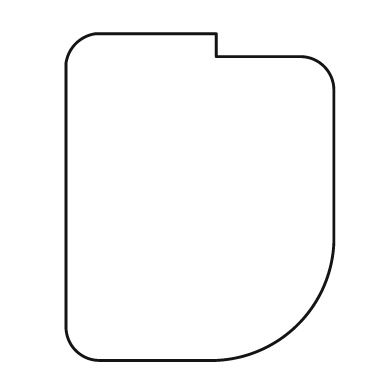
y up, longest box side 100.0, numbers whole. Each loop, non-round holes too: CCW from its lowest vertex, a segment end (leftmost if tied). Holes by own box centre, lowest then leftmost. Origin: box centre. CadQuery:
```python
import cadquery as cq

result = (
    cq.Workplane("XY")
    .moveTo(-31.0, -50.0)
    .lineTo(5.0, -50.0)
    .threePointArc((30.0, -39.0), (41.0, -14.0))
    .lineTo(41.0, 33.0)
    .threePointArc((38.0, 40.0), (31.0, 43.0))
    .lineTo(5.0, 43.0)
    .lineTo(5.0, 50.0)
    .lineTo(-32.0, 50.0)
    .threePointArc((-38.0, 47.0), (-41.0, 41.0))
    .lineTo(-41.0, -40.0)
    .threePointArc((-38.0, -47.0), (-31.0, -50.0))
    .close()
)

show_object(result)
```